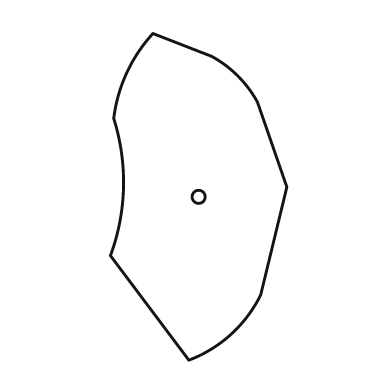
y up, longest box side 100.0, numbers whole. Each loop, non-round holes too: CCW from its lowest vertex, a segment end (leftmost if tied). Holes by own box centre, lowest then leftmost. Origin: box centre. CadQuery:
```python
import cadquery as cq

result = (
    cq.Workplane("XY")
    .moveTo(-3.0, -50.0)
    .threePointArc((10.0, -42.0), (19.0, -30.0))
    .lineTo(27.0, 3.0)
    .lineTo(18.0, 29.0)
    .threePointArc((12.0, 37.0), (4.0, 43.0))
    .lineTo(-14.0, 50.0)
    .threePointArc((-22.0, 38.0), (-26.0, 24.0))
    .threePointArc((-23.0, 3.0), (-27.0, -18.0))
    .close()
    .moveTo(0.0, 0.0)
    .circle(2.0)
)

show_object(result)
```